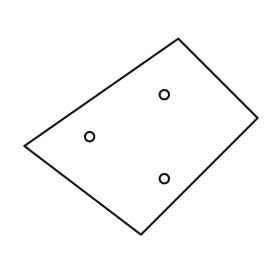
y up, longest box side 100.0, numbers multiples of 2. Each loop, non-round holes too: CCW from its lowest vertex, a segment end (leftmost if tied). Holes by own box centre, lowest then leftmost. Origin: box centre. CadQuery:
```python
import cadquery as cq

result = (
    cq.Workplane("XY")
    .moveTo(0.0, -42.0)
    .lineTo(50.0, 8.0)
    .lineTo(16.0, 42.0)
    .lineTo(-50.0, -4.0)
    .close()
    .moveTo(10.0, -18.0)
    .circle(2.0)
    .moveTo(-22.0, 0.0)
    .circle(2.0)
    .moveTo(10.0, 18.0)
    .circle(2.0)
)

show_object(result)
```